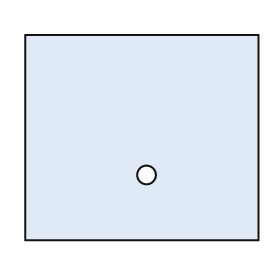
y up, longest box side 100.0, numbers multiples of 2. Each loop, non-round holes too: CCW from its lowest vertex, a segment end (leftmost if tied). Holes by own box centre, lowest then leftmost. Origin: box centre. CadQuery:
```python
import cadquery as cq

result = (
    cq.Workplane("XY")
    .moveTo(-50.0, -44.0)
    .lineTo(50.0, -44.0)
    .lineTo(50.0, 44.0)
    .lineTo(-50.0, 44.0)
    .close()
    .moveTo(2.0, -16.0)
    .circle(4.0)
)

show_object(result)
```